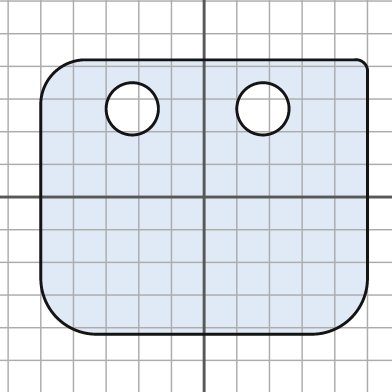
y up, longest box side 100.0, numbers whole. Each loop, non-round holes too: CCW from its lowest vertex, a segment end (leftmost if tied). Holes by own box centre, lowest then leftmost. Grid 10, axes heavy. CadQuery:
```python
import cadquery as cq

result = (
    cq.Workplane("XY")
    .moveTo(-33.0, -42.0)
    .lineTo(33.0, -42.0)
    .threePointArc((45.0, -37.0), (50.0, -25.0))
    .lineTo(50.0, 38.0)
    .threePointArc((49.0, 41.0), (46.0, 42.0))
    .lineTo(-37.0, 42.0)
    .threePointArc((-46.0, 38.0), (-50.0, 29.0))
    .lineTo(-50.0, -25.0)
    .threePointArc((-45.0, -37.0), (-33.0, -42.0))
    .close()
    .moveTo(-22.0, 27.0)
    .circle(8.0)
    .moveTo(18.0, 27.0)
    .circle(8.0)
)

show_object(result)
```